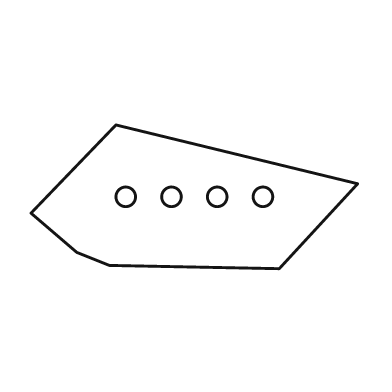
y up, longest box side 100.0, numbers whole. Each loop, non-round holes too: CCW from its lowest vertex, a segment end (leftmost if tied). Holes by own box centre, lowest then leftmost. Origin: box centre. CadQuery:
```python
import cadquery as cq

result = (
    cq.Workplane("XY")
    .moveTo(26.0, -22.0)
    .lineTo(50.0, 4.0)
    .lineTo(-24.0, 22.0)
    .lineTo(-50.0, -5.0)
    .lineTo(-36.0, -17.0)
    .lineTo(-26.0, -21.0)
    .close()
    .moveTo(-21.0, 0.0)
    .circle(3.0)
    .moveTo(-7.0, 0.0)
    .circle(3.0)
    .moveTo(7.0, 0.0)
    .circle(3.0)
    .moveTo(21.0, 0.0)
    .circle(3.0)
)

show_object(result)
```